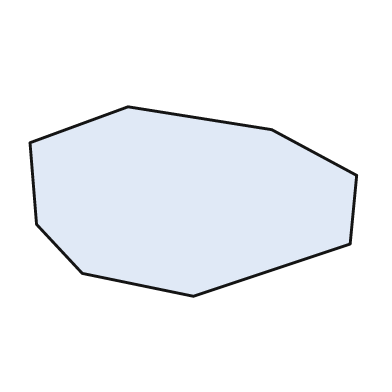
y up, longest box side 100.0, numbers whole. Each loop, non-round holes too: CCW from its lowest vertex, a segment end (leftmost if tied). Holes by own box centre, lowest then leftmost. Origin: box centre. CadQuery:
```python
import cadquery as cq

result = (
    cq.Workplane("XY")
    .moveTo(0.0, -29.0)
    .lineTo(48.0, -13.0)
    .lineTo(50.0, 8.0)
    .lineTo(24.0, 22.0)
    .lineTo(-20.0, 29.0)
    .lineTo(-50.0, 18.0)
    .lineTo(-48.0, -7.0)
    .lineTo(-34.0, -22.0)
    .close()
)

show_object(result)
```